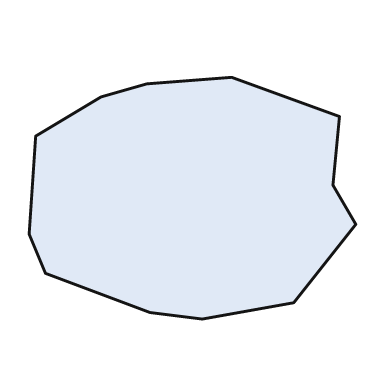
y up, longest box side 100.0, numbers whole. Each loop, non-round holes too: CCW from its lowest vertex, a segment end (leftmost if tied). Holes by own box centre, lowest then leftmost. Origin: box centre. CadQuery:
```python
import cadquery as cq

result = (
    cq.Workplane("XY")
    .moveTo(3.0, -37.0)
    .lineTo(31.0, -32.0)
    .lineTo(50.0, -8.0)
    .lineTo(43.0, 4.0)
    .lineTo(45.0, 25.0)
    .lineTo(12.0, 37.0)
    .lineTo(-14.0, 35.0)
    .lineTo(-28.0, 31.0)
    .lineTo(-48.0, 19.0)
    .lineTo(-50.0, -11.0)
    .lineTo(-45.0, -23.0)
    .lineTo(-13.0, -35.0)
    .close()
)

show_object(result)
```